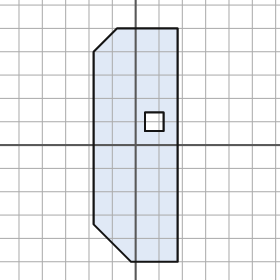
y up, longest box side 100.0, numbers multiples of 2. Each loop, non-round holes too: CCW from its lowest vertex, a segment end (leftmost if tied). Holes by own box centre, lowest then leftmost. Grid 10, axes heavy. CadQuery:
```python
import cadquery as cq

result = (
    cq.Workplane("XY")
    .moveTo(-2.0, -50.0)
    .lineTo(18.0, -50.0)
    .lineTo(18.0, 50.0)
    .lineTo(-8.0, 50.0)
    .lineTo(-18.0, 40.0)
    .lineTo(-18.0, -34.0)
    .close()
    .moveTo(4.0, 6.0)
    .lineTo(12.0, 6.0)
    .lineTo(12.0, 14.0)
    .lineTo(4.0, 14.0)
    .close()
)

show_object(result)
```